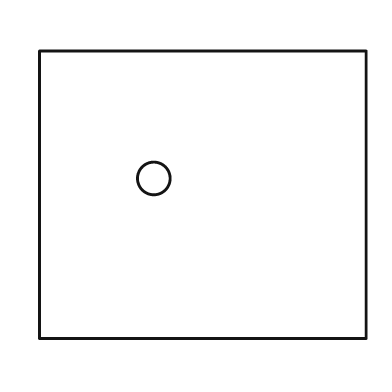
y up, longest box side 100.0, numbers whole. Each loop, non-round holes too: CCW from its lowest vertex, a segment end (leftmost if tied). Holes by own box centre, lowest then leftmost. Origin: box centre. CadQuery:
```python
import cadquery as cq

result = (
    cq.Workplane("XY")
    .moveTo(-50.0, -44.0)
    .lineTo(50.0, -44.0)
    .lineTo(50.0, 44.0)
    .lineTo(-50.0, 44.0)
    .close()
    .moveTo(-15.0, 5.0)
    .circle(5.0)
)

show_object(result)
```